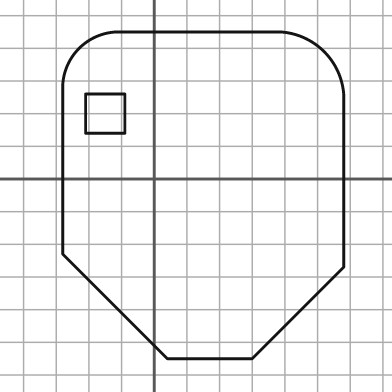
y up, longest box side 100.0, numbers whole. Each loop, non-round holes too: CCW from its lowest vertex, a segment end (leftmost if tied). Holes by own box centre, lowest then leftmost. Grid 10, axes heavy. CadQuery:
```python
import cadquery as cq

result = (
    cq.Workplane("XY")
    .moveTo(4.0, -55.0)
    .lineTo(30.0, -55.0)
    .lineTo(58.0, -27.0)
    .lineTo(58.0, 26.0)
    .threePointArc((52.0, 39.0), (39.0, 45.0))
    .lineTo(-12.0, 45.0)
    .threePointArc((-23.0, 40.0), (-28.0, 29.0))
    .lineTo(-28.0, -23.0)
    .close()
    .moveTo(-21.0, 14.0)
    .lineTo(-9.0, 14.0)
    .lineTo(-9.0, 26.0)
    .lineTo(-21.0, 26.0)
    .close()
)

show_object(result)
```